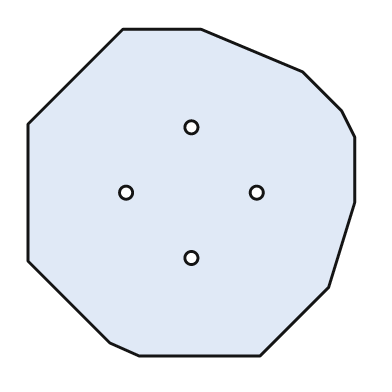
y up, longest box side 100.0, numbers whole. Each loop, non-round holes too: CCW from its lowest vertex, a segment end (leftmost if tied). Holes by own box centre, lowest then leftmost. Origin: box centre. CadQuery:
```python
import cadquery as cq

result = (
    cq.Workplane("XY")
    .moveTo(-16.0, -50.0)
    .lineTo(21.0, -50.0)
    .lineTo(42.0, -29.0)
    .lineTo(50.0, -3.0)
    .lineTo(50.0, 17.0)
    .lineTo(46.0, 25.0)
    .lineTo(34.0, 37.0)
    .lineTo(3.0, 50.0)
    .lineTo(-21.0, 50.0)
    .lineTo(-50.0, 21.0)
    .lineTo(-50.0, -21.0)
    .lineTo(-25.0, -46.0)
    .close()
    .moveTo(0.0, -20.0)
    .circle(2.0)
    .moveTo(-20.0, 0.0)
    .circle(2.0)
    .moveTo(20.0, 0.0)
    .circle(2.0)
    .moveTo(0.0, 20.0)
    .circle(2.0)
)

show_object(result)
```